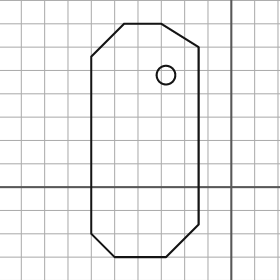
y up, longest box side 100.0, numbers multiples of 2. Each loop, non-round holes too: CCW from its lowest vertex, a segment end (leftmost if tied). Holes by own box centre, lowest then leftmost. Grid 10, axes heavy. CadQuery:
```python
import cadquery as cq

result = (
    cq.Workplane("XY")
    .moveTo(-50.0, -30.0)
    .lineTo(-28.0, -30.0)
    .lineTo(-14.0, -16.0)
    .lineTo(-14.0, 60.0)
    .lineTo(-30.0, 70.0)
    .lineTo(-46.0, 70.0)
    .lineTo(-60.0, 56.0)
    .lineTo(-60.0, -20.0)
    .close()
    .moveTo(-28.0, 48.0)
    .circle(4.0)
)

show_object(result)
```